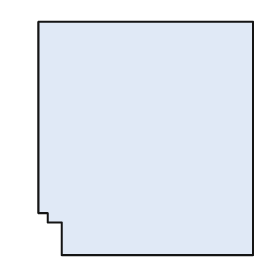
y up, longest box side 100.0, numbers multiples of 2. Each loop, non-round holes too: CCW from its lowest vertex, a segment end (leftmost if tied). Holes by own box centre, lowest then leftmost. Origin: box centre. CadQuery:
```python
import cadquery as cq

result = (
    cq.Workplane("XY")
    .moveTo(-36.0, -50.0)
    .lineTo(46.0, -50.0)
    .lineTo(46.0, 50.0)
    .lineTo(-46.0, 50.0)
    .lineTo(-46.0, -32.0)
    .lineTo(-42.0, -32.0)
    .lineTo(-42.0, -36.0)
    .lineTo(-36.0, -36.0)
    .close()
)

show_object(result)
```